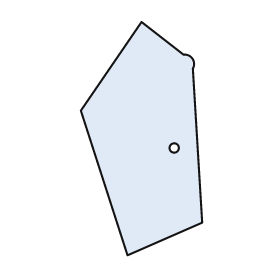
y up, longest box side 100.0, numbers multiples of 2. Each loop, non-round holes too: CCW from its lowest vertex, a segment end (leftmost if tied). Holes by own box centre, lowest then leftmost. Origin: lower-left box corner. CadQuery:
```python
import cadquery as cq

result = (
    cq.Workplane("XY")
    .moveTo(20.0, 0.0)
    .lineTo(52.0, 14.0)
    .lineTo(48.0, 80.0)
    .threePointArc((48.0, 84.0), (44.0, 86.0))
    .lineTo(26.0, 100.0)
    .lineTo(0.0, 62.0)
    .close()
    .moveTo(40.0, 46.0)
    .circle(2.0)
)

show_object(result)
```